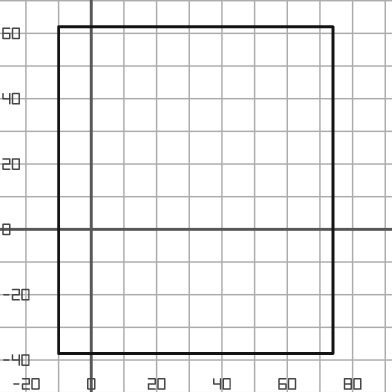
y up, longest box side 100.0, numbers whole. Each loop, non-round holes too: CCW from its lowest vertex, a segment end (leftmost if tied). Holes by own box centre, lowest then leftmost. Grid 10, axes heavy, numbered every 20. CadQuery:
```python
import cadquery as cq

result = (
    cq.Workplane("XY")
    .moveTo(-10.0, -38.0)
    .lineTo(74.0, -38.0)
    .lineTo(74.0, 62.0)
    .lineTo(-10.0, 62.0)
    .close()
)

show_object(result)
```